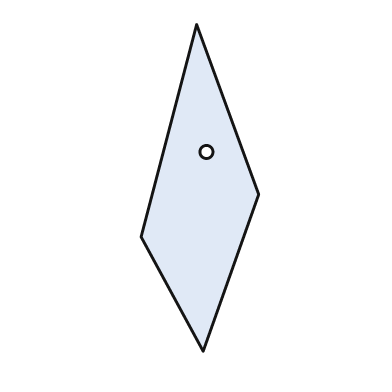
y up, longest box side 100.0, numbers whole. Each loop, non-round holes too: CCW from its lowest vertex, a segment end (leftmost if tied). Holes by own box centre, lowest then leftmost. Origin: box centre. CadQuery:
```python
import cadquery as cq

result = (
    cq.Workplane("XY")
    .moveTo(1.0, -50.0)
    .lineTo(18.0, -2.0)
    .lineTo(-1.0, 50.0)
    .lineTo(-18.0, -15.0)
    .close()
    .moveTo(2.0, 11.0)
    .circle(2.0)
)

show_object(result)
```